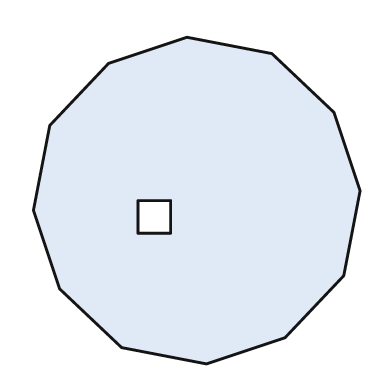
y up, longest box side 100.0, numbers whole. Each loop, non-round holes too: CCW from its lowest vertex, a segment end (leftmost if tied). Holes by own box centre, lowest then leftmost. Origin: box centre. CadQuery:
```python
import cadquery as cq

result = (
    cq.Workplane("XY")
    .moveTo(3.0, -50.0)
    .lineTo(27.0, -42.0)
    .lineTo(45.0, -23.0)
    .lineTo(50.0, 3.0)
    .lineTo(42.0, 27.0)
    .lineTo(23.0, 45.0)
    .lineTo(-3.0, 50.0)
    .lineTo(-27.0, 42.0)
    .lineTo(-45.0, 23.0)
    .lineTo(-50.0, -3.0)
    .lineTo(-42.0, -27.0)
    .lineTo(-23.0, -45.0)
    .close()
    .moveTo(-18.0, -10.0)
    .lineTo(-8.0, -10.0)
    .lineTo(-8.0, 0.0)
    .lineTo(-18.0, 0.0)
    .close()
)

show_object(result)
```